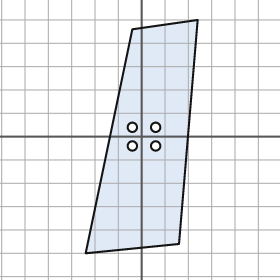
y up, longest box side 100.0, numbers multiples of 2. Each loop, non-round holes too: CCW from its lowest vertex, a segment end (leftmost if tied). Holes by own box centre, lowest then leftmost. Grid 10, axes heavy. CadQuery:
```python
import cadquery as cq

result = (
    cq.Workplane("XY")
    .moveTo(-24.0, -50.0)
    .lineTo(16.0, -46.0)
    .lineTo(24.0, 50.0)
    .lineTo(-4.0, 46.0)
    .close()
    .moveTo(-4.0, -4.0)
    .circle(2.0)
    .moveTo(6.0, -4.0)
    .circle(2.0)
    .moveTo(-4.0, 4.0)
    .circle(2.0)
    .moveTo(6.0, 4.0)
    .circle(2.0)
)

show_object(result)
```